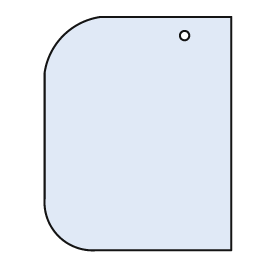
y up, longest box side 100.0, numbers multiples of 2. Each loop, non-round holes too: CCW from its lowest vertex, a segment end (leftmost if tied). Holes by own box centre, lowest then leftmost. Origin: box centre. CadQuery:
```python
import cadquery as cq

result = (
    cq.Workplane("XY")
    .moveTo(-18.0, -50.0)
    .lineTo(40.0, -50.0)
    .lineTo(40.0, 50.0)
    .lineTo(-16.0, 50.0)
    .threePointArc((-32.0, 42.0), (-40.0, 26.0))
    .lineTo(-40.0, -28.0)
    .threePointArc((-34.0, -44.0), (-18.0, -50.0))
    .close()
    .moveTo(20.0, 42.0)
    .circle(2.0)
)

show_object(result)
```